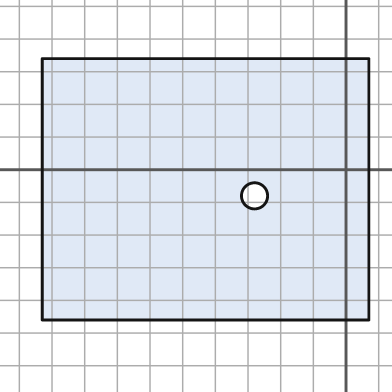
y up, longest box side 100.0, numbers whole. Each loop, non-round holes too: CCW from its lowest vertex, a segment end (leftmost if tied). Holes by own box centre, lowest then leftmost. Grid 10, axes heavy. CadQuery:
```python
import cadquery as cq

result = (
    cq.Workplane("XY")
    .moveTo(-93.0, -46.0)
    .lineTo(7.0, -46.0)
    .lineTo(7.0, 34.0)
    .lineTo(-93.0, 34.0)
    .close()
    .moveTo(-28.0, -8.0)
    .circle(4.0)
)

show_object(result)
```